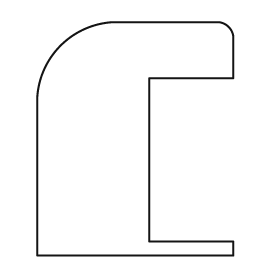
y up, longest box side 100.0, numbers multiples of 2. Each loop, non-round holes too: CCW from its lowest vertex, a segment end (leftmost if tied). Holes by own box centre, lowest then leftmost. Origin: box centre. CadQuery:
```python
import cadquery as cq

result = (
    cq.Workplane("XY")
    .moveTo(-42.0, -50.0)
    .lineTo(42.0, -50.0)
    .lineTo(42.0, -44.0)
    .lineTo(6.0, -44.0)
    .lineTo(6.0, 26.0)
    .lineTo(42.0, 26.0)
    .lineTo(42.0, 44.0)
    .threePointArc((40.0, 48.0), (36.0, 50.0))
    .lineTo(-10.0, 50.0)
    .threePointArc((-32.0, 40.0), (-42.0, 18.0))
    .close()
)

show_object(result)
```